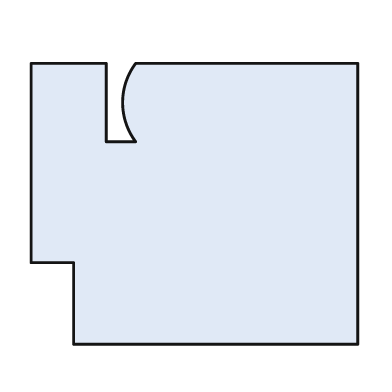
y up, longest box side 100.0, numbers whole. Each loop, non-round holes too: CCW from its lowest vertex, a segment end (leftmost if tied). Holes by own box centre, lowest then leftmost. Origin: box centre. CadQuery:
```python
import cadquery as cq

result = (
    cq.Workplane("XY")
    .moveTo(-37.0, -43.0)
    .lineTo(50.0, -43.0)
    .lineTo(50.0, 43.0)
    .lineTo(-18.0, 43.0)
    .threePointArc((-22.0, 31.0), (-18.0, 19.0))
    .lineTo(-27.0, 19.0)
    .lineTo(-27.0, 43.0)
    .lineTo(-50.0, 43.0)
    .lineTo(-50.0, -18.0)
    .lineTo(-37.0, -18.0)
    .close()
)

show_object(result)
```